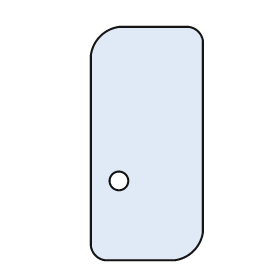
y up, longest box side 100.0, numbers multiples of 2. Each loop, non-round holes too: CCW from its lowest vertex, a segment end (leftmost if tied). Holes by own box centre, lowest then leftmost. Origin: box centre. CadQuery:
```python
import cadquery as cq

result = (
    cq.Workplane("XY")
    .moveTo(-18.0, -50.0)
    .lineTo(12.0, -50.0)
    .threePointArc((20.0, -46.0), (24.0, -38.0))
    .lineTo(24.0, 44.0)
    .threePointArc((22.0, 48.0), (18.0, 50.0))
    .lineTo(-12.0, 50.0)
    .threePointArc((-20.0, 46.0), (-24.0, 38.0))
    .lineTo(-24.0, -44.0)
    .threePointArc((-22.0, -48.0), (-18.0, -50.0))
    .close()
    .moveTo(-12.0, -16.0)
    .circle(4.0)
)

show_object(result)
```